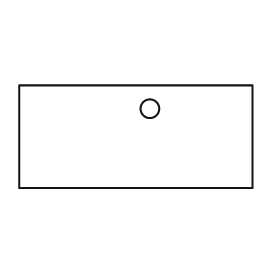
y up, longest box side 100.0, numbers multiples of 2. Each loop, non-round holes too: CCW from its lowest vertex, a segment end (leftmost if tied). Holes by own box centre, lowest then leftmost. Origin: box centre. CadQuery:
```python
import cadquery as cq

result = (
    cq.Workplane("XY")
    .moveTo(-50.0, -22.0)
    .lineTo(50.0, -22.0)
    .lineTo(50.0, 22.0)
    .lineTo(-50.0, 22.0)
    .close()
    .moveTo(6.0, 12.0)
    .circle(4.0)
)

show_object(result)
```